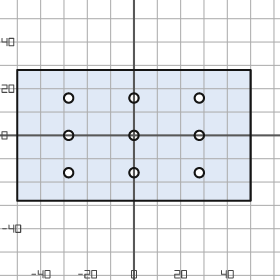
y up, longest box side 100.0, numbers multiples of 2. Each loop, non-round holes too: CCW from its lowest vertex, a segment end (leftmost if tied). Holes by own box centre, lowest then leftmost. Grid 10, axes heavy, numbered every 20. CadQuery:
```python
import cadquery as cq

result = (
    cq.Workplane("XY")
    .moveTo(-50.0, -28.0)
    .lineTo(50.0, -28.0)
    .lineTo(50.0, 28.0)
    .lineTo(-50.0, 28.0)
    .close()
    .moveTo(-28.0, -16.0)
    .circle(2.0)
    .moveTo(0.0, -16.0)
    .circle(2.0)
    .moveTo(28.0, -16.0)
    .circle(2.0)
    .moveTo(-28.0, 0.0)
    .circle(2.0)
    .moveTo(0.0, 0.0)
    .circle(2.0)
    .moveTo(28.0, 0.0)
    .circle(2.0)
    .moveTo(-28.0, 16.0)
    .circle(2.0)
    .moveTo(0.0, 16.0)
    .circle(2.0)
    .moveTo(28.0, 16.0)
    .circle(2.0)
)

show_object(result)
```